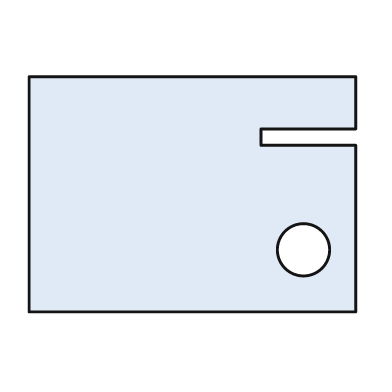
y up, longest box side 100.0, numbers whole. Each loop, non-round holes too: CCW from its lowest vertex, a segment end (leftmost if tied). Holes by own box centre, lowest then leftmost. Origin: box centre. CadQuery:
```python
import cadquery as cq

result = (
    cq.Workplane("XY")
    .moveTo(-50.0, -36.0)
    .lineTo(50.0, -36.0)
    .lineTo(50.0, 15.0)
    .lineTo(21.0, 15.0)
    .lineTo(21.0, 20.0)
    .lineTo(50.0, 20.0)
    .lineTo(50.0, 36.0)
    .lineTo(-50.0, 36.0)
    .close()
    .moveTo(34.0, -17.0)
    .circle(8.0)
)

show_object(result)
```